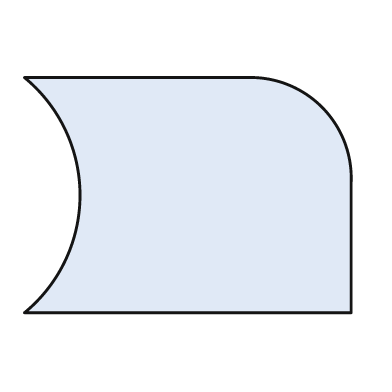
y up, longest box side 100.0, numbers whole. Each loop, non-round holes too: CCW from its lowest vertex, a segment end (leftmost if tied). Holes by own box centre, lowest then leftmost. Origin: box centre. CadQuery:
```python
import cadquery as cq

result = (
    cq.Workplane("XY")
    .moveTo(-50.0, -36.0)
    .lineTo(50.0, -36.0)
    .lineTo(50.0, 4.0)
    .threePointArc((41.0, 27.0), (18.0, 36.0))
    .lineTo(-50.0, 36.0)
    .threePointArc((-33.0, 0.0), (-50.0, -36.0))
    .close()
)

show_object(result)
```